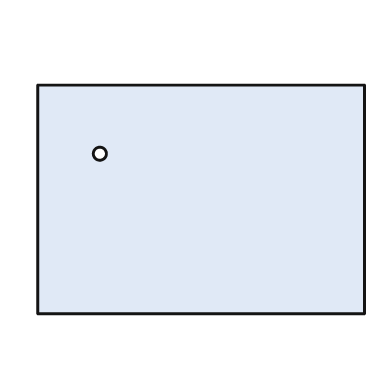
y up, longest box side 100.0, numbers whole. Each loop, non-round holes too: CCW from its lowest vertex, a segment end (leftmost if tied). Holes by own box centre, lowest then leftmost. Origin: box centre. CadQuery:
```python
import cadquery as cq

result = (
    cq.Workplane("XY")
    .moveTo(-50.0, -35.0)
    .lineTo(50.0, -35.0)
    .lineTo(50.0, 35.0)
    .lineTo(-50.0, 35.0)
    .close()
    .moveTo(-31.0, 14.0)
    .circle(2.0)
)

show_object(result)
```